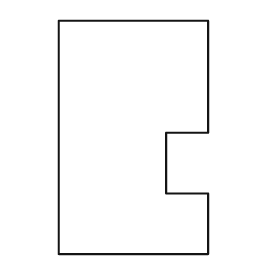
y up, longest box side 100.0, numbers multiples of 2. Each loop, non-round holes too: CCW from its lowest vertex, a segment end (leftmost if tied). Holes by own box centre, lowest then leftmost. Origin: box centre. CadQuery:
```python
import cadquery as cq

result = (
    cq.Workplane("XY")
    .moveTo(-32.0, -50.0)
    .lineTo(32.0, -50.0)
    .lineTo(32.0, -24.0)
    .lineTo(14.0, -24.0)
    .lineTo(14.0, 2.0)
    .lineTo(32.0, 2.0)
    .lineTo(32.0, 50.0)
    .lineTo(-32.0, 50.0)
    .close()
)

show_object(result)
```